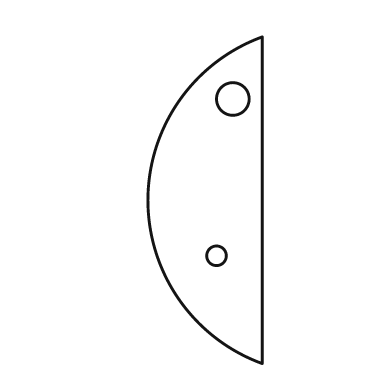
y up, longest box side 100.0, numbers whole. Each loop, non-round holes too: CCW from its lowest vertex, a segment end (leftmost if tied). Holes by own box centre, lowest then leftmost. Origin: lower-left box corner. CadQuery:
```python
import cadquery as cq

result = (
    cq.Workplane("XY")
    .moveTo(35.0, 0.0)
    .lineTo(35.0, 100.0)
    .threePointArc((0.0, 50.0), (35.0, 0.0))
    .close()
    .moveTo(21.0, 33.0)
    .circle(3.0)
    .moveTo(26.0, 81.0)
    .circle(5.0)
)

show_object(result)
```